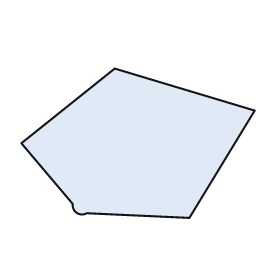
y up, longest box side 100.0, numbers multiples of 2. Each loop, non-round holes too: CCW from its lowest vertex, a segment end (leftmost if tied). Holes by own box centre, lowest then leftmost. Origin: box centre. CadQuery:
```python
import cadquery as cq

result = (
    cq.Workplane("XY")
    .moveTo(22.0, -32.0)
    .lineTo(50.0, 14.0)
    .lineTo(-10.0, 32.0)
    .lineTo(-50.0, 0.0)
    .lineTo(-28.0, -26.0)
    .threePointArc((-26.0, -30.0), (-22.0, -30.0))
    .close()
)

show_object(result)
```